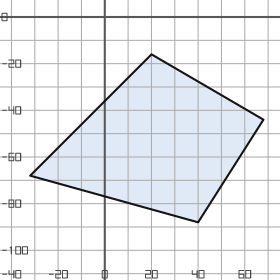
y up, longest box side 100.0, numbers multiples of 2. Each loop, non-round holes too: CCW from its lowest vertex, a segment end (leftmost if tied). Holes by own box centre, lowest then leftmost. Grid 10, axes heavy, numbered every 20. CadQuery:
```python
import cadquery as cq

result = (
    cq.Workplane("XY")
    .moveTo(40.0, -88.0)
    .lineTo(68.0, -44.0)
    .lineTo(20.0, -16.0)
    .lineTo(-32.0, -68.0)
    .close()
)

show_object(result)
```